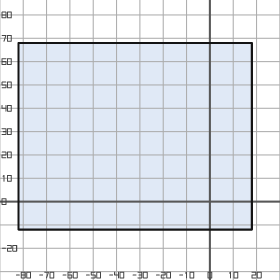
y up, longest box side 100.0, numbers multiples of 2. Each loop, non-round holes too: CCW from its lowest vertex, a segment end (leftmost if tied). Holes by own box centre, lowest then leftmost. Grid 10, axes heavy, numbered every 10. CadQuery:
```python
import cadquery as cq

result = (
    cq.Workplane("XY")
    .moveTo(-82.0, -12.0)
    .lineTo(18.0, -12.0)
    .lineTo(18.0, 68.0)
    .lineTo(-82.0, 68.0)
    .close()
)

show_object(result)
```